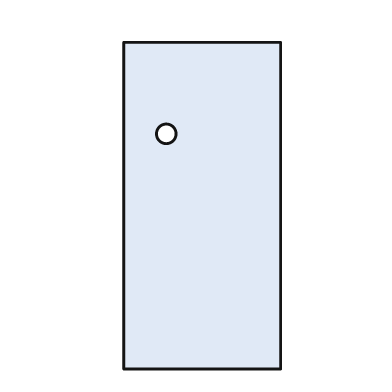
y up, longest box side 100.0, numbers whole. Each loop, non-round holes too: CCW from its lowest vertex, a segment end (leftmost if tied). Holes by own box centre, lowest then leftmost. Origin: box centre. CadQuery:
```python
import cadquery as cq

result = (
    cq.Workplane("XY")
    .moveTo(-24.0, -50.0)
    .lineTo(24.0, -50.0)
    .lineTo(24.0, 50.0)
    .lineTo(-24.0, 50.0)
    .close()
    .moveTo(-11.0, 22.0)
    .circle(3.0)
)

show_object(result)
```